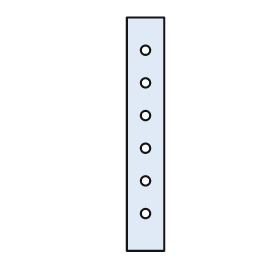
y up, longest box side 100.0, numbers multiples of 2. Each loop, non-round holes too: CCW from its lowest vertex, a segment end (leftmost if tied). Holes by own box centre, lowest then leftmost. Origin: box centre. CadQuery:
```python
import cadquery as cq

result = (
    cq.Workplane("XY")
    .moveTo(-8.0, -50.0)
    .lineTo(8.0, -50.0)
    .lineTo(8.0, 50.0)
    .lineTo(-8.0, 50.0)
    .close()
    .moveTo(0.0, -34.0)
    .circle(2.0)
    .moveTo(0.0, -20.0)
    .circle(2.0)
    .moveTo(0.0, -6.0)
    .circle(2.0)
    .moveTo(0.0, 8.0)
    .circle(2.0)
    .moveTo(0.0, 22.0)
    .circle(2.0)
    .moveTo(0.0, 36.0)
    .circle(2.0)
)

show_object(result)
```